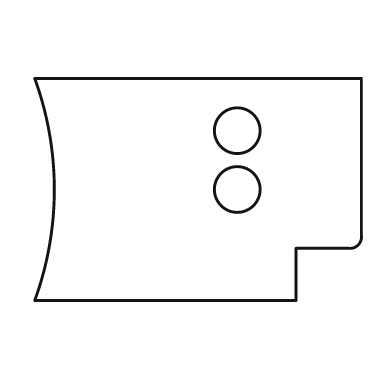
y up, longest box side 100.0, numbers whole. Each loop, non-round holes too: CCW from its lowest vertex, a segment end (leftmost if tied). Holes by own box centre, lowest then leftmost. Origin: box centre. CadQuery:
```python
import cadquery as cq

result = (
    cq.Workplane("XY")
    .moveTo(-50.0, -34.0)
    .lineTo(30.0, -34.0)
    .lineTo(30.0, -18.0)
    .lineTo(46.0, -18.0)
    .threePointArc((49.0, -17.0), (50.0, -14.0))
    .lineTo(50.0, 34.0)
    .lineTo(-50.0, 34.0)
    .threePointArc((-44.0, 0.0), (-50.0, -34.0))
    .close()
    .moveTo(12.0, 0.0)
    .circle(7.0)
    .moveTo(12.0, 18.0)
    .circle(7.0)
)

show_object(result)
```